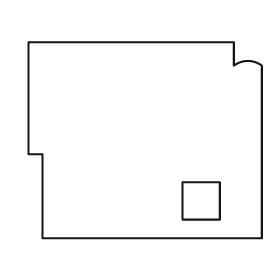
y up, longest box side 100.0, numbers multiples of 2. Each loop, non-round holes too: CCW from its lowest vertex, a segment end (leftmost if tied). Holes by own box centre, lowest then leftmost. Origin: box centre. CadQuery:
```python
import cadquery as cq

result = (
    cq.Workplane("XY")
    .moveTo(-44.0, -42.0)
    .lineTo(50.0, -42.0)
    .lineTo(50.0, 32.0)
    .threePointArc((44.0, 34.0), (38.0, 32.0))
    .lineTo(38.0, 42.0)
    .lineTo(-50.0, 42.0)
    .lineTo(-50.0, -6.0)
    .lineTo(-44.0, -6.0)
    .close()
    .moveTo(16.0, -34.0)
    .lineTo(32.0, -34.0)
    .lineTo(32.0, -18.0)
    .lineTo(16.0, -18.0)
    .close()
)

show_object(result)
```